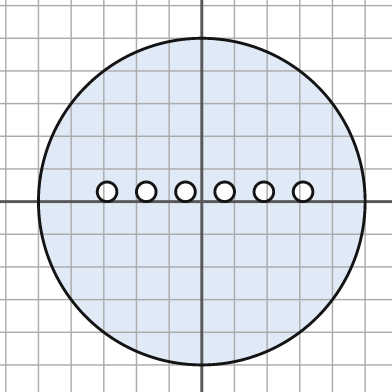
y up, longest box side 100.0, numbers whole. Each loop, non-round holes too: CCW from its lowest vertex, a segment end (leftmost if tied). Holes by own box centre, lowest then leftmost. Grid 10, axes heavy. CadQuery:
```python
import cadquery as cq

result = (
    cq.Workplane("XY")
    .moveTo(0.0, 0.0)
    .circle(50.0)
    .moveTo(-29.0, 3.0)
    .circle(3.0)
    .moveTo(-17.0, 3.0)
    .circle(3.0)
    .moveTo(-5.0, 3.0)
    .circle(3.0)
    .moveTo(7.0, 3.0)
    .circle(3.0)
    .moveTo(19.0, 3.0)
    .circle(3.0)
    .moveTo(31.0, 3.0)
    .circle(3.0)
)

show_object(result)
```